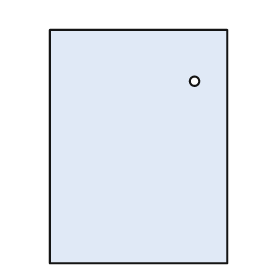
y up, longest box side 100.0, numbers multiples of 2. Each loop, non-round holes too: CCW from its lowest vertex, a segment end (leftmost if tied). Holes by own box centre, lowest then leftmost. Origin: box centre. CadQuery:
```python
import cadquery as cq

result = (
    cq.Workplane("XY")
    .moveTo(-38.0, -50.0)
    .lineTo(38.0, -50.0)
    .lineTo(38.0, 50.0)
    .lineTo(-38.0, 50.0)
    .close()
    .moveTo(24.0, 28.0)
    .circle(2.0)
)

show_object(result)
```